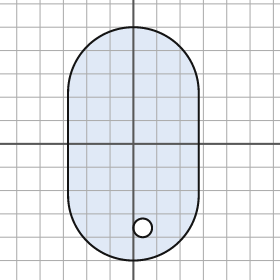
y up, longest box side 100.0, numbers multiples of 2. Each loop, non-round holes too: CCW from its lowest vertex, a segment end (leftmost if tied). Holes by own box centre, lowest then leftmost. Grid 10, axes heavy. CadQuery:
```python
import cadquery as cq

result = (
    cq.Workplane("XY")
    .moveTo(-28.0, -22.0)
    .threePointArc((0.0, -50.0), (28.0, -22.0))
    .lineTo(28.0, 22.0)
    .threePointArc((0.0, 50.0), (-28.0, 22.0))
    .close()
    .moveTo(4.0, -36.0)
    .circle(4.0)
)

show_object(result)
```